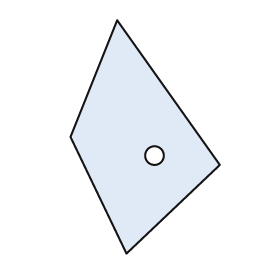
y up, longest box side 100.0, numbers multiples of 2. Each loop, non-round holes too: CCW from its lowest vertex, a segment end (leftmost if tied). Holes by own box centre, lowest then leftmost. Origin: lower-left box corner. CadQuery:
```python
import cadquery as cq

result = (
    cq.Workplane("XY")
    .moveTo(24.0, 0.0)
    .lineTo(64.0, 38.0)
    .lineTo(20.0, 100.0)
    .lineTo(0.0, 50.0)
    .close()
    .moveTo(36.0, 42.0)
    .circle(4.0)
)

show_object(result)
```